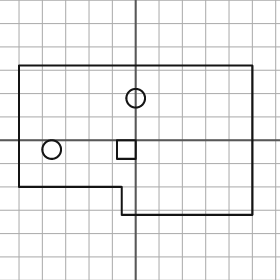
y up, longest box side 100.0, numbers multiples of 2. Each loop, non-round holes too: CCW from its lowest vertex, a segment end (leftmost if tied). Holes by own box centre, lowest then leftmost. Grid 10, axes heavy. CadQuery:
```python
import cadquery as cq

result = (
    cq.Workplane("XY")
    .moveTo(-6.0, -32.0)
    .lineTo(50.0, -32.0)
    .lineTo(50.0, 32.0)
    .lineTo(-50.0, 32.0)
    .lineTo(-50.0, -20.0)
    .lineTo(-6.0, -20.0)
    .close()
    .moveTo(-36.0, -4.0)
    .circle(4.0)
    .moveTo(-8.0, -8.0)
    .lineTo(0.0, -8.0)
    .lineTo(0.0, 0.0)
    .lineTo(-8.0, 0.0)
    .close()
    .moveTo(0.0, 18.0)
    .circle(4.0)
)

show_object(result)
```